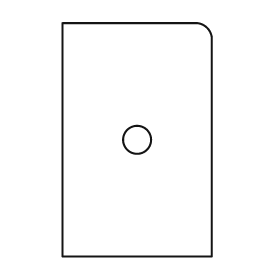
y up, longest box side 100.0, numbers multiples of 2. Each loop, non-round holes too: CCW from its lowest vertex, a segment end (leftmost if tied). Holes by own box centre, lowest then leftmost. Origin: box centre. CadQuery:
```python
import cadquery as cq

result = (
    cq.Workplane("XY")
    .moveTo(-32.0, -50.0)
    .lineTo(32.0, -50.0)
    .lineTo(32.0, 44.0)
    .threePointArc((30.0, 48.0), (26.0, 50.0))
    .lineTo(-32.0, 50.0)
    .close()
    .moveTo(0.0, 0.0)
    .circle(6.0)
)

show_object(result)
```